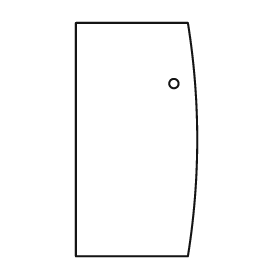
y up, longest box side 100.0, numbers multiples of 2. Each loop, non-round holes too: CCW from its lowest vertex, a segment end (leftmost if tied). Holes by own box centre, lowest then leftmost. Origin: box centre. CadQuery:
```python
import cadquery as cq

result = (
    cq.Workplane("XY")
    .moveTo(-26.0, -50.0)
    .lineTo(22.0, -50.0)
    .threePointArc((26.0, 0.0), (22.0, 50.0))
    .lineTo(-26.0, 50.0)
    .close()
    .moveTo(16.0, 24.0)
    .circle(2.0)
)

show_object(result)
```